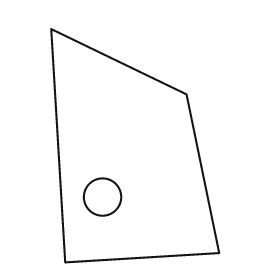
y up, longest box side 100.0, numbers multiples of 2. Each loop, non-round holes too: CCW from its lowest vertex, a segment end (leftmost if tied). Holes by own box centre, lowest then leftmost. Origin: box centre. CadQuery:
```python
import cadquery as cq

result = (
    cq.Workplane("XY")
    .moveTo(-30.0, -50.0)
    .lineTo(36.0, -46.0)
    .lineTo(22.0, 22.0)
    .lineTo(-36.0, 50.0)
    .close()
    .moveTo(-14.0, -22.0)
    .circle(8.0)
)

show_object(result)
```